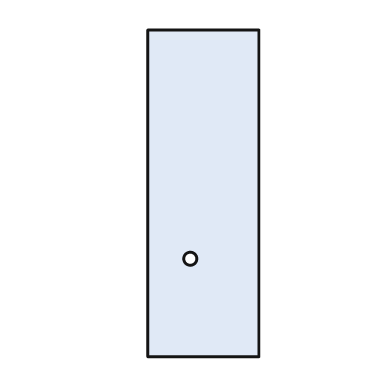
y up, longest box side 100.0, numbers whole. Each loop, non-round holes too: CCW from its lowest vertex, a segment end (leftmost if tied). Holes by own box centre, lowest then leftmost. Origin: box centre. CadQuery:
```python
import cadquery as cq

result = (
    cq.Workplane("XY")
    .moveTo(-17.0, -50.0)
    .lineTo(17.0, -50.0)
    .lineTo(17.0, 50.0)
    .lineTo(-17.0, 50.0)
    .close()
    .moveTo(-4.0, -20.0)
    .circle(2.0)
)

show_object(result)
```